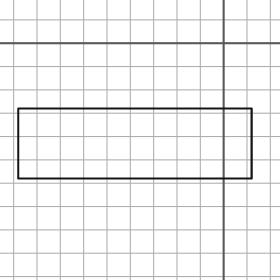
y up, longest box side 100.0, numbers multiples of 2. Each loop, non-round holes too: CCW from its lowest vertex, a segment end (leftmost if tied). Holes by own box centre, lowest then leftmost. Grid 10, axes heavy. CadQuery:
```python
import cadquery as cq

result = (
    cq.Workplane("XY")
    .moveTo(-88.0, -58.0)
    .lineTo(12.0, -58.0)
    .lineTo(12.0, -28.0)
    .lineTo(-88.0, -28.0)
    .close()
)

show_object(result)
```